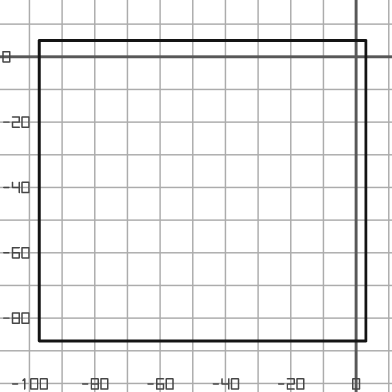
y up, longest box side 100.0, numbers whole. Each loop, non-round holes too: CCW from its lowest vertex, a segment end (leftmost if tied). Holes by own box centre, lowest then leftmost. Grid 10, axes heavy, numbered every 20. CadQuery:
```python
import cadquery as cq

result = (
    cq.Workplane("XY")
    .moveTo(-97.0, -87.0)
    .lineTo(3.0, -87.0)
    .lineTo(3.0, 5.0)
    .lineTo(-97.0, 5.0)
    .close()
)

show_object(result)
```